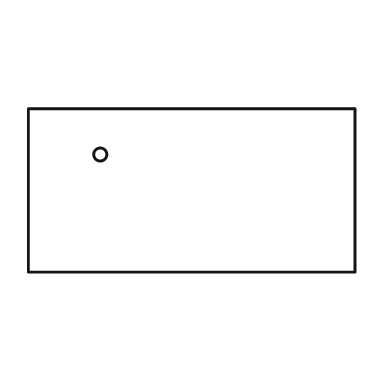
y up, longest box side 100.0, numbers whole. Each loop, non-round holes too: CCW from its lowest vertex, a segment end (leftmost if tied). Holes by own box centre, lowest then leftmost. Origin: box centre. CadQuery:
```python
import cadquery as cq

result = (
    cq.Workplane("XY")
    .moveTo(-50.0, -25.0)
    .lineTo(50.0, -25.0)
    .lineTo(50.0, 25.0)
    .lineTo(-50.0, 25.0)
    .close()
    .moveTo(-28.0, 11.0)
    .circle(2.0)
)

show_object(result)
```